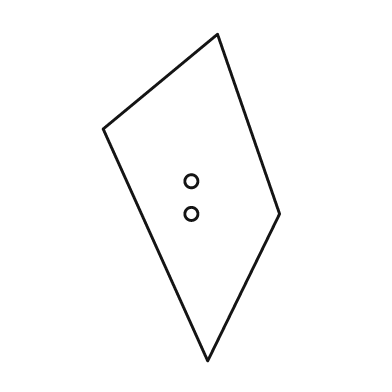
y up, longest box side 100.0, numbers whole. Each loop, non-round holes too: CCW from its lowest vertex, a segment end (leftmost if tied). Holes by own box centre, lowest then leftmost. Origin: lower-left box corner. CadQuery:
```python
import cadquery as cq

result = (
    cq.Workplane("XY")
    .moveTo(32.0, 0.0)
    .lineTo(54.0, 45.0)
    .lineTo(35.0, 100.0)
    .lineTo(0.0, 71.0)
    .close()
    .moveTo(27.0, 45.0)
    .circle(2.0)
    .moveTo(27.0, 55.0)
    .circle(2.0)
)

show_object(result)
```